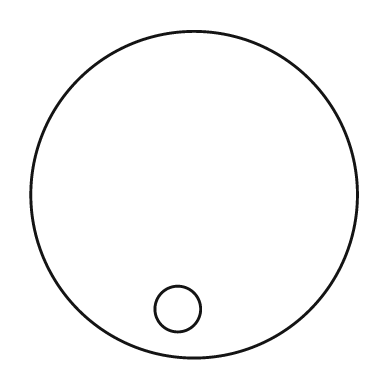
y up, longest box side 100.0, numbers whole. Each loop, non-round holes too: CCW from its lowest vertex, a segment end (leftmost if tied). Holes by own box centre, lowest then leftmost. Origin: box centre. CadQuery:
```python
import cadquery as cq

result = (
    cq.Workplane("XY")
    .moveTo(0.0, 0.0)
    .circle(50.0)
    .moveTo(-5.0, -35.0)
    .circle(7.0)
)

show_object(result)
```